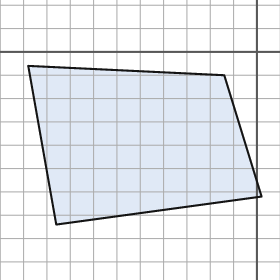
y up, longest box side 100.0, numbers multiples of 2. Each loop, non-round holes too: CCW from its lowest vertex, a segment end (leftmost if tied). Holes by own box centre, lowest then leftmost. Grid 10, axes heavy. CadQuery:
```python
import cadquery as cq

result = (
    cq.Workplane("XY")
    .moveTo(-86.0, -74.0)
    .lineTo(2.0, -62.0)
    .lineTo(-14.0, -10.0)
    .lineTo(-98.0, -6.0)
    .close()
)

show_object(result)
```